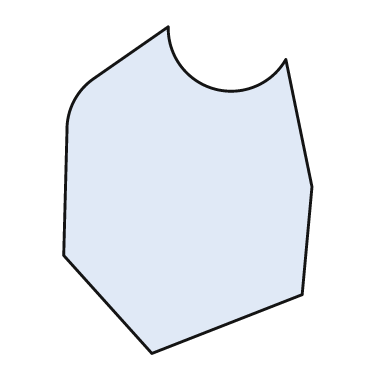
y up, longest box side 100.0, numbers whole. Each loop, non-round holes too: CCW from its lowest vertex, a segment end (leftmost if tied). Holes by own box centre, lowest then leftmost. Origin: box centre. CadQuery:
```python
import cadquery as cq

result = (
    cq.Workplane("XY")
    .moveTo(-11.0, -50.0)
    .lineTo(35.0, -32.0)
    .lineTo(38.0, 1.0)
    .lineTo(30.0, 40.0)
    .threePointArc((8.0, 31.0), (-6.0, 50.0))
    .lineTo(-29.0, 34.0)
    .threePointArc((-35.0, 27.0), (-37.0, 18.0))
    .lineTo(-38.0, -20.0)
    .close()
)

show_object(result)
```